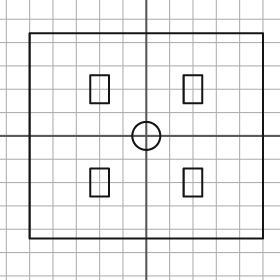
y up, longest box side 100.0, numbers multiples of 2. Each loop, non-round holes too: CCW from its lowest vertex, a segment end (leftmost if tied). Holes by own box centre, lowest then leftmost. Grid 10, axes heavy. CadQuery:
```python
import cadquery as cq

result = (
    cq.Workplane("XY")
    .moveTo(-50.0, -44.0)
    .lineTo(50.0, -44.0)
    .lineTo(50.0, 44.0)
    .lineTo(-50.0, 44.0)
    .close()
    .moveTo(-24.0, -26.0)
    .lineTo(-16.0, -26.0)
    .lineTo(-16.0, -14.0)
    .lineTo(-24.0, -14.0)
    .close()
    .moveTo(16.0, -26.0)
    .lineTo(24.0, -26.0)
    .lineTo(24.0, -14.0)
    .lineTo(16.0, -14.0)
    .close()
    .moveTo(0.0, 0.0)
    .circle(6.0)
    .moveTo(-24.0, 14.0)
    .lineTo(-16.0, 14.0)
    .lineTo(-16.0, 26.0)
    .lineTo(-24.0, 26.0)
    .close()
    .moveTo(16.0, 14.0)
    .lineTo(24.0, 14.0)
    .lineTo(24.0, 26.0)
    .lineTo(16.0, 26.0)
    .close()
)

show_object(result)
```